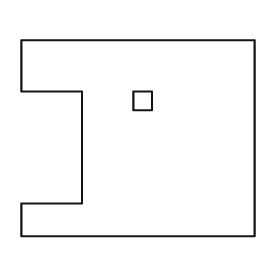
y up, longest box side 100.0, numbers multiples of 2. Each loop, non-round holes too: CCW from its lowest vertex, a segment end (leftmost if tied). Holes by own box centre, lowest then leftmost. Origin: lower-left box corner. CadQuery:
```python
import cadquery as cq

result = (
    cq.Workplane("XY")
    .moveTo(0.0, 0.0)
    .lineTo(100.0, 0.0)
    .lineTo(100.0, 84.0)
    .lineTo(0.0, 84.0)
    .lineTo(0.0, 62.0)
    .lineTo(26.0, 62.0)
    .lineTo(26.0, 14.0)
    .lineTo(0.0, 14.0)
    .close()
    .moveTo(48.0, 54.0)
    .lineTo(56.0, 54.0)
    .lineTo(56.0, 62.0)
    .lineTo(48.0, 62.0)
    .close()
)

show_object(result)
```